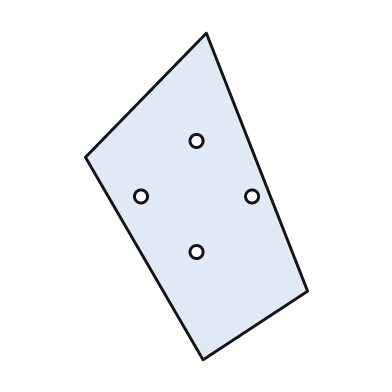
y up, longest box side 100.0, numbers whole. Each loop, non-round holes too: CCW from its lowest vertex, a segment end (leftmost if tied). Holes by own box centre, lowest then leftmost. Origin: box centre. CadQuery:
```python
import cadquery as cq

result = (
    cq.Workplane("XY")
    .moveTo(2.0, -50.0)
    .lineTo(34.0, -29.0)
    .lineTo(3.0, 50.0)
    .lineTo(-34.0, 12.0)
    .close()
    .moveTo(0.0, -17.0)
    .circle(2.0)
    .moveTo(-17.0, 0.0)
    .circle(2.0)
    .moveTo(17.0, 0.0)
    .circle(2.0)
    .moveTo(0.0, 17.0)
    .circle(2.0)
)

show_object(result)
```